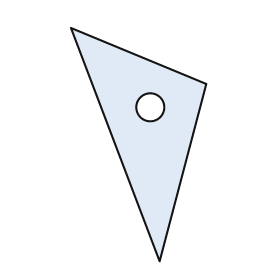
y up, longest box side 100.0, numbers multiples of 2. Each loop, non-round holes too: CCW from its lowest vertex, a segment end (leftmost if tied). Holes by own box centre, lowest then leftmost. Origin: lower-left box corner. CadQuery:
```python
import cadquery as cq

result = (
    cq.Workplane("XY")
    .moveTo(38.0, 0.0)
    .lineTo(58.0, 76.0)
    .lineTo(0.0, 100.0)
    .close()
    .moveTo(34.0, 66.0)
    .circle(6.0)
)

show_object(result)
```